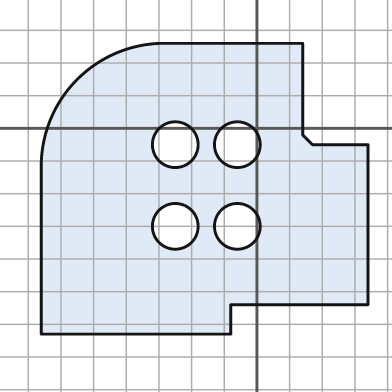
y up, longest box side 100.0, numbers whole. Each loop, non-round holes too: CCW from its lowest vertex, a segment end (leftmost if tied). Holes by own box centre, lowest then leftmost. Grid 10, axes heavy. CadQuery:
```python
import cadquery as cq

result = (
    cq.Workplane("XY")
    .moveTo(-66.0, -63.0)
    .lineTo(-8.0, -63.0)
    .lineTo(-8.0, -54.0)
    .lineTo(34.0, -54.0)
    .lineTo(34.0, -5.0)
    .lineTo(17.0, -5.0)
    .lineTo(14.0, -2.0)
    .lineTo(14.0, 26.0)
    .lineTo(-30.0, 26.0)
    .threePointArc((-55.0, 15.0), (-66.0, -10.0))
    .close()
    .moveTo(-25.0, -30.0)
    .circle(7.0)
    .moveTo(-6.0, -30.0)
    .circle(7.0)
    .moveTo(-25.0, -5.0)
    .circle(7.0)
    .moveTo(-6.0, -5.0)
    .circle(7.0)
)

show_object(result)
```